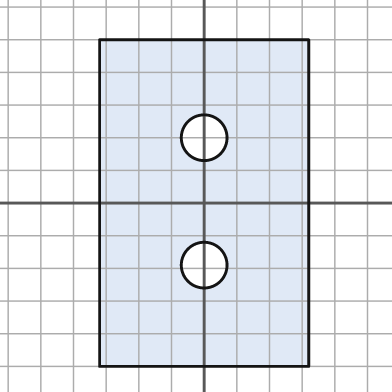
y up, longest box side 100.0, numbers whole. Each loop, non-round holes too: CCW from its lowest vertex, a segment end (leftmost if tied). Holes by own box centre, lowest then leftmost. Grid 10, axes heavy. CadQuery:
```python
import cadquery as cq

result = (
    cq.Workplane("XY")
    .moveTo(-32.0, -50.0)
    .lineTo(32.0, -50.0)
    .lineTo(32.0, 50.0)
    .lineTo(-32.0, 50.0)
    .close()
    .moveTo(0.0, -19.0)
    .circle(7.0)
    .moveTo(0.0, 20.0)
    .circle(7.0)
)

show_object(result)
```